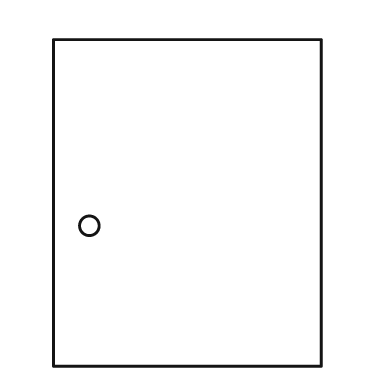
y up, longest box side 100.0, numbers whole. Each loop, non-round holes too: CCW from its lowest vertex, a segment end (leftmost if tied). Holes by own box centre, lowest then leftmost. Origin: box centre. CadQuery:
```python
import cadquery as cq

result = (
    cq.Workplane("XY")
    .moveTo(-41.0, -50.0)
    .lineTo(41.0, -50.0)
    .lineTo(41.0, 50.0)
    .lineTo(-41.0, 50.0)
    .close()
    .moveTo(-30.0, -7.0)
    .circle(3.0)
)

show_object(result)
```